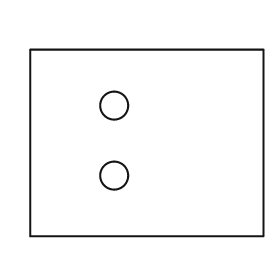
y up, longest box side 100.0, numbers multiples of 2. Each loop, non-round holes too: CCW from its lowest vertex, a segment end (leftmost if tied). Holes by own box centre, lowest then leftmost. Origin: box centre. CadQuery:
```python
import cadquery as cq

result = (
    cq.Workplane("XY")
    .moveTo(-50.0, -40.0)
    .lineTo(50.0, -40.0)
    .lineTo(50.0, 40.0)
    .lineTo(-50.0, 40.0)
    .close()
    .moveTo(-14.0, -14.0)
    .circle(6.0)
    .moveTo(-14.0, 16.0)
    .circle(6.0)
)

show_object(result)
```